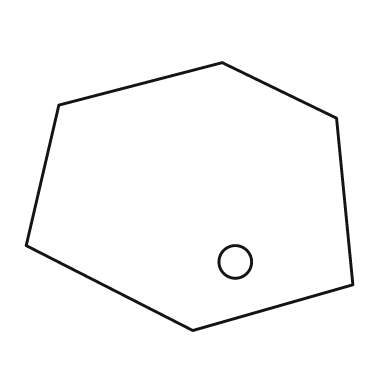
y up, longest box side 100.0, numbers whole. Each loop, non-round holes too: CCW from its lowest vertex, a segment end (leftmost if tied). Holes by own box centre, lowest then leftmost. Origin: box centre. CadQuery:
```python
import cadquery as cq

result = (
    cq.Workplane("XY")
    .moveTo(1.0, -41.0)
    .lineTo(50.0, -27.0)
    .lineTo(45.0, 24.0)
    .lineTo(10.0, 41.0)
    .lineTo(-40.0, 28.0)
    .lineTo(-50.0, -15.0)
    .close()
    .moveTo(14.0, -20.0)
    .circle(5.0)
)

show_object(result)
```